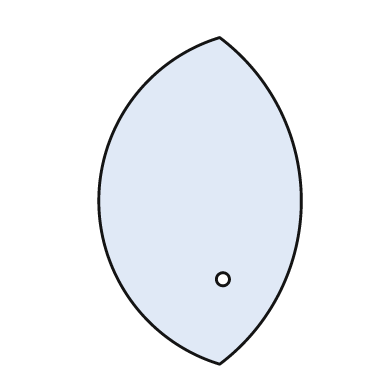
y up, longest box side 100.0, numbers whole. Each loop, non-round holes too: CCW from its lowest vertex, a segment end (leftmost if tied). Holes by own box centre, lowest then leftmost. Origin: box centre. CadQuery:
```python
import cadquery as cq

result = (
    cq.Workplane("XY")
    .moveTo(6.0, -50.0)
    .threePointArc((31.0, 0.0), (6.0, 50.0))
    .threePointArc((-31.0, 0.0), (6.0, -50.0))
    .close()
    .moveTo(7.0, -24.0)
    .circle(2.0)
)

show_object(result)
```